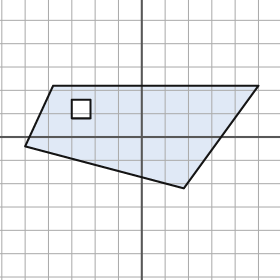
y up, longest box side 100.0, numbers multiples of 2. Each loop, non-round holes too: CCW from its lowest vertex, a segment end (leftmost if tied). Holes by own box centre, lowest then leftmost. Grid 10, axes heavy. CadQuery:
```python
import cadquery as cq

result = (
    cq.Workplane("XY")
    .moveTo(18.0, -22.0)
    .lineTo(50.0, 22.0)
    .lineTo(-38.0, 22.0)
    .lineTo(-50.0, -4.0)
    .close()
    .moveTo(-30.0, 8.0)
    .lineTo(-22.0, 8.0)
    .lineTo(-22.0, 16.0)
    .lineTo(-30.0, 16.0)
    .close()
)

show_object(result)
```